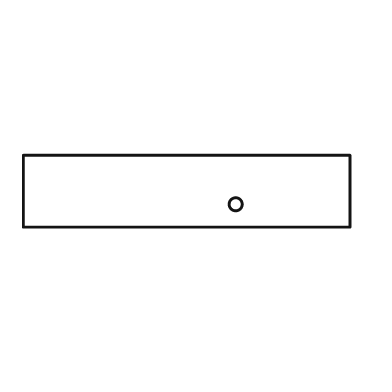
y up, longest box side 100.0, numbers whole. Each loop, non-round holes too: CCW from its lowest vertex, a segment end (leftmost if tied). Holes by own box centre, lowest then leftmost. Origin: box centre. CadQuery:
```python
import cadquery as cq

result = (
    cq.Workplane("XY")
    .moveTo(-50.0, -11.0)
    .lineTo(50.0, -11.0)
    .lineTo(50.0, 11.0)
    .lineTo(-50.0, 11.0)
    .close()
    .moveTo(15.0, -4.0)
    .circle(2.0)
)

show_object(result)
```